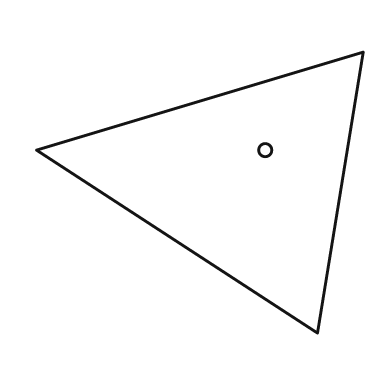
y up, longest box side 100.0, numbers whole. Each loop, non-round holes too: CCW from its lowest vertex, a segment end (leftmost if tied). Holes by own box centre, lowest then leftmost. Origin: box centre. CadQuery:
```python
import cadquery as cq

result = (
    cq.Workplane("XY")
    .moveTo(36.0, -43.0)
    .lineTo(50.0, 43.0)
    .lineTo(-50.0, 13.0)
    .close()
    .moveTo(20.0, 13.0)
    .circle(2.0)
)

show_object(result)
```